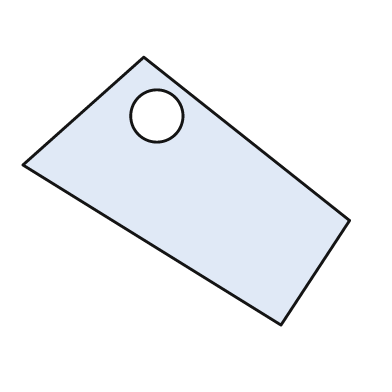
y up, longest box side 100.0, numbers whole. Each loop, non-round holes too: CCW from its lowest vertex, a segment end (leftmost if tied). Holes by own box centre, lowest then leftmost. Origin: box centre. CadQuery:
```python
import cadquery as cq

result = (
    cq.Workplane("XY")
    .moveTo(29.0, -41.0)
    .lineTo(50.0, -9.0)
    .lineTo(-13.0, 41.0)
    .lineTo(-50.0, 8.0)
    .close()
    .moveTo(-9.0, 23.0)
    .circle(8.0)
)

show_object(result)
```